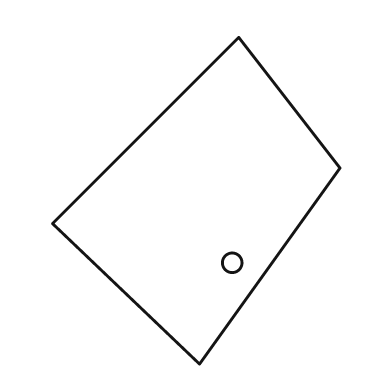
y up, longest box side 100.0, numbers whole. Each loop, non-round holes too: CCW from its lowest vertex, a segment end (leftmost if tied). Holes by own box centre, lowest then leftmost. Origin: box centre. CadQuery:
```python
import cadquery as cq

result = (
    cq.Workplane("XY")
    .moveTo(1.0, -50.0)
    .lineTo(44.0, 10.0)
    .lineTo(13.0, 50.0)
    .lineTo(-44.0, -7.0)
    .close()
    .moveTo(11.0, -19.0)
    .circle(3.0)
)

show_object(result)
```